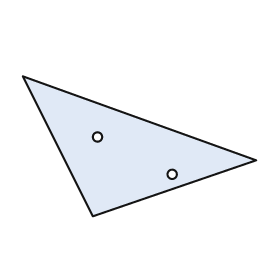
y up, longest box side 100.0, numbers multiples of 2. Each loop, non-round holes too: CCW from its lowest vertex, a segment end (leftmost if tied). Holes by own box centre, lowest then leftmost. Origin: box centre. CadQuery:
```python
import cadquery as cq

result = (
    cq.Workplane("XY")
    .moveTo(-20.0, -30.0)
    .lineTo(50.0, -6.0)
    .lineTo(-50.0, 30.0)
    .close()
    .moveTo(14.0, -12.0)
    .circle(2.0)
    .moveTo(-18.0, 4.0)
    .circle(2.0)
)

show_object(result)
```